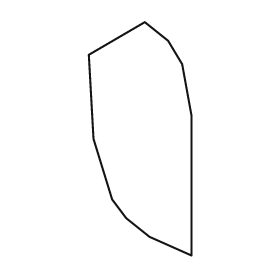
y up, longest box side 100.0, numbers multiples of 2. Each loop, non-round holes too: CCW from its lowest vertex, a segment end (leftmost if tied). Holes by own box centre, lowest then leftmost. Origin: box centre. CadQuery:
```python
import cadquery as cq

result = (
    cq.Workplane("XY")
    .moveTo(22.0, -50.0)
    .lineTo(22.0, 10.0)
    .lineTo(18.0, 32.0)
    .lineTo(12.0, 42.0)
    .lineTo(2.0, 50.0)
    .lineTo(-22.0, 36.0)
    .lineTo(-20.0, 0.0)
    .lineTo(-12.0, -26.0)
    .lineTo(-6.0, -34.0)
    .lineTo(4.0, -42.0)
    .close()
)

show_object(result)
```